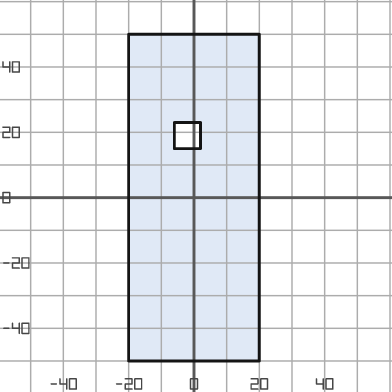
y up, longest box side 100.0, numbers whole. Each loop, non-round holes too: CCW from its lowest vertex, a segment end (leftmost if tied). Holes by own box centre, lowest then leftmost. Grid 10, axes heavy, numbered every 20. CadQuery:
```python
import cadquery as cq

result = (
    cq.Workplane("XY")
    .moveTo(-20.0, -50.0)
    .lineTo(20.0, -50.0)
    .lineTo(20.0, 50.0)
    .lineTo(-20.0, 50.0)
    .close()
    .moveTo(-6.0, 15.0)
    .lineTo(2.0, 15.0)
    .lineTo(2.0, 23.0)
    .lineTo(-6.0, 23.0)
    .close()
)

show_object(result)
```